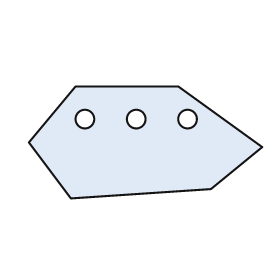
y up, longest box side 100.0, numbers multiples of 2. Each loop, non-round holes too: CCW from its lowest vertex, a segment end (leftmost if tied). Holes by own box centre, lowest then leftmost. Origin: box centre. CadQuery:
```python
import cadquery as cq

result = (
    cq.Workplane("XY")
    .moveTo(-32.0, -24.0)
    .lineTo(28.0, -20.0)
    .lineTo(50.0, -2.0)
    .lineTo(14.0, 24.0)
    .lineTo(-30.0, 24.0)
    .lineTo(-50.0, 0.0)
    .close()
    .moveTo(-26.0, 10.0)
    .circle(4.0)
    .moveTo(-4.0, 10.0)
    .circle(4.0)
    .moveTo(18.0, 10.0)
    .circle(4.0)
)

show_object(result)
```